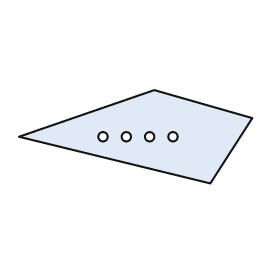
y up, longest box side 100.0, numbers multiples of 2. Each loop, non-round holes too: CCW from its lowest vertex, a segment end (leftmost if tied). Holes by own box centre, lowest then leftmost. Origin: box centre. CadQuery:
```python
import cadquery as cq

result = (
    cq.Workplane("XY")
    .moveTo(32.0, -20.0)
    .lineTo(50.0, 8.0)
    .lineTo(8.0, 20.0)
    .lineTo(-50.0, 0.0)
    .close()
    .moveTo(-14.0, 0.0)
    .circle(2.0)
    .moveTo(-4.0, 0.0)
    .circle(2.0)
    .moveTo(6.0, 0.0)
    .circle(2.0)
    .moveTo(16.0, 0.0)
    .circle(2.0)
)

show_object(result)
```